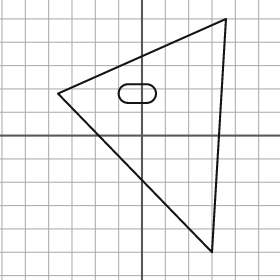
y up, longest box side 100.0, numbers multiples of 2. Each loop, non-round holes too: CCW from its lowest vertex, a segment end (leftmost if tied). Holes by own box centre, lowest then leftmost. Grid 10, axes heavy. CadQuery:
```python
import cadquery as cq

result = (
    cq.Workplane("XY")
    .moveTo(30.0, -50.0)
    .lineTo(36.0, 50.0)
    .lineTo(-36.0, 18.0)
    .close()
    .moveTo(-6.0, 14.0)
    .lineTo(2.0, 14.0)
    .threePointArc((6.0, 18.0), (2.0, 22.0))
    .lineTo(-6.0, 22.0)
    .threePointArc((-10.0, 18.0), (-6.0, 14.0))
    .close()
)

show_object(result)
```